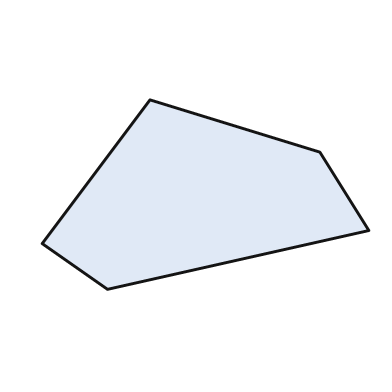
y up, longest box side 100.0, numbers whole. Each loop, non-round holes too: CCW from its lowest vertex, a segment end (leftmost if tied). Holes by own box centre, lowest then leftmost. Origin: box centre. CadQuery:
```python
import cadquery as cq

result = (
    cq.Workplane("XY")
    .moveTo(-30.0, -29.0)
    .lineTo(50.0, -11.0)
    .lineTo(35.0, 13.0)
    .lineTo(-17.0, 29.0)
    .lineTo(-50.0, -15.0)
    .close()
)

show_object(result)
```